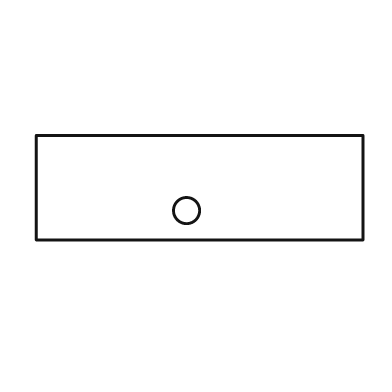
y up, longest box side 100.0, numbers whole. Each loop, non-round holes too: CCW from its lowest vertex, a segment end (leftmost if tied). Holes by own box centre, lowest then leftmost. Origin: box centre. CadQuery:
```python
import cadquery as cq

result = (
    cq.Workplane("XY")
    .moveTo(-50.0, -16.0)
    .lineTo(50.0, -16.0)
    .lineTo(50.0, 16.0)
    .lineTo(-50.0, 16.0)
    .close()
    .moveTo(-4.0, -7.0)
    .circle(4.0)
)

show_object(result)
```